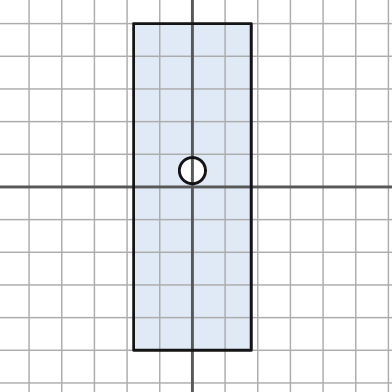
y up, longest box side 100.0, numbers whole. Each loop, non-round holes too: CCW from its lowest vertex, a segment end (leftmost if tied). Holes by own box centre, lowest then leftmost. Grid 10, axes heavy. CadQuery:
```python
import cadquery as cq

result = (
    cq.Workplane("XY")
    .moveTo(-18.0, -50.0)
    .lineTo(18.0, -50.0)
    .lineTo(18.0, 50.0)
    .lineTo(-18.0, 50.0)
    .close()
    .moveTo(0.0, 5.0)
    .circle(4.0)
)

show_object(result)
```